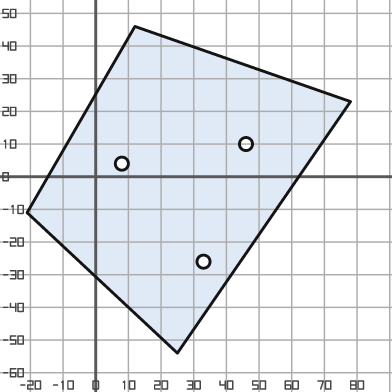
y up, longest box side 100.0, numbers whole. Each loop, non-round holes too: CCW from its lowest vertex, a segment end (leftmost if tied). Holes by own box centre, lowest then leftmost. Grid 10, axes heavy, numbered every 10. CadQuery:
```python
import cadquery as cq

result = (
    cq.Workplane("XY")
    .moveTo(25.0, -54.0)
    .lineTo(78.0, 23.0)
    .lineTo(12.0, 46.0)
    .lineTo(-21.0, -11.0)
    .close()
    .moveTo(33.0, -26.0)
    .circle(2.0)
    .moveTo(8.0, 4.0)
    .circle(2.0)
    .moveTo(46.0, 10.0)
    .circle(2.0)
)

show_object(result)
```